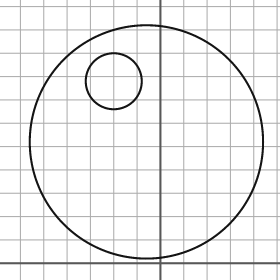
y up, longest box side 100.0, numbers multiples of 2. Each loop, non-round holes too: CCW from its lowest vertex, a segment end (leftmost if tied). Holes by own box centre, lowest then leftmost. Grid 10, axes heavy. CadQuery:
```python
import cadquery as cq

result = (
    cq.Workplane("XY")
    .moveTo(-6.0, 52.0)
    .circle(50.0)
    .moveTo(-20.0, 78.0)
    .circle(12.0)
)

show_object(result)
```